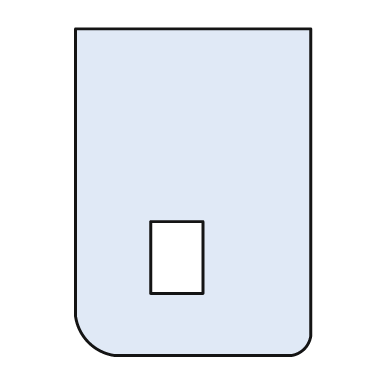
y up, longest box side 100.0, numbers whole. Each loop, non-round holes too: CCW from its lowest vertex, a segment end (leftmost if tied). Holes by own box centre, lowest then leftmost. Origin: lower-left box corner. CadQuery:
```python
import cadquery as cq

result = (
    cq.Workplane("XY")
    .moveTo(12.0, 0.0)
    .lineTo(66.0, 0.0)
    .threePointArc((70.0, 2.0), (72.0, 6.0))
    .lineTo(72.0, 100.0)
    .lineTo(0.0, 100.0)
    .lineTo(0.0, 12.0)
    .threePointArc((4.0, 4.0), (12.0, 0.0))
    .close()
    .moveTo(23.0, 19.0)
    .lineTo(39.0, 19.0)
    .lineTo(39.0, 41.0)
    .lineTo(23.0, 41.0)
    .close()
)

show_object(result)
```